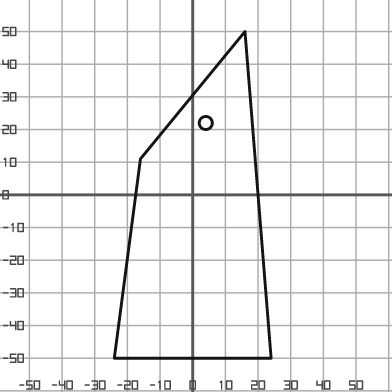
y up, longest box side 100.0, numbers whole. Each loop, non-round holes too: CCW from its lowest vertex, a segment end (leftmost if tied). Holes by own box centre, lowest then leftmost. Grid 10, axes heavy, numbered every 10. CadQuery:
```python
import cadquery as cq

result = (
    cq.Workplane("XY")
    .moveTo(-24.0, -50.0)
    .lineTo(24.0, -50.0)
    .lineTo(16.0, 50.0)
    .lineTo(-16.0, 11.0)
    .close()
    .moveTo(4.0, 22.0)
    .circle(2.0)
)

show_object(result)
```